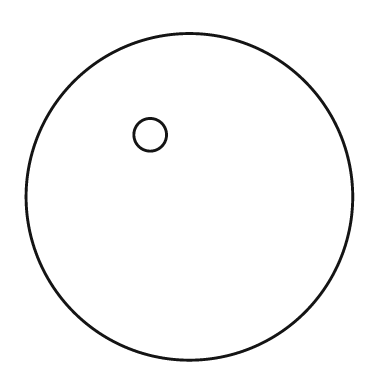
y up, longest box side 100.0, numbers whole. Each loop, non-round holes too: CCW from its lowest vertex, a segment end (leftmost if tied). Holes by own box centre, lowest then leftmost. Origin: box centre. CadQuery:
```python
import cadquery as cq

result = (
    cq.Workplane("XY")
    .moveTo(0.0, 0.0)
    .circle(50.0)
    .moveTo(-12.0, 19.0)
    .circle(5.0)
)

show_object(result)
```